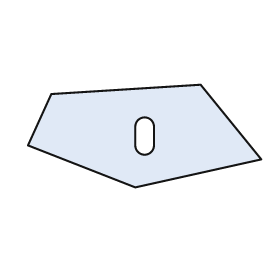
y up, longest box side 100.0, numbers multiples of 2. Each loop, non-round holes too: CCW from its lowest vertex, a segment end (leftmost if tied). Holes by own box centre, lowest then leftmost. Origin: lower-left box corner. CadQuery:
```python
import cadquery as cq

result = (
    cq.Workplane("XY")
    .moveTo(46.0, 0.0)
    .lineTo(100.0, 12.0)
    .lineTo(74.0, 44.0)
    .lineTo(10.0, 40.0)
    .lineTo(0.0, 18.0)
    .close()
    .moveTo(46.0, 18.0)
    .threePointArc((50.0, 14.0), (54.0, 18.0))
    .lineTo(54.0, 26.0)
    .threePointArc((50.0, 30.0), (46.0, 26.0))
    .close()
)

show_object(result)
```